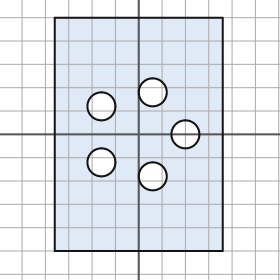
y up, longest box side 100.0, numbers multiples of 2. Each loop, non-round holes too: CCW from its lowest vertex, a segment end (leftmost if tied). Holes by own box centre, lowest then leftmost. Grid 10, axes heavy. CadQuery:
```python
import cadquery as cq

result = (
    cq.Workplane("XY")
    .moveTo(-36.0, -50.0)
    .lineTo(36.0, -50.0)
    .lineTo(36.0, 50.0)
    .lineTo(-36.0, 50.0)
    .close()
    .moveTo(6.0, -18.0)
    .circle(6.0)
    .moveTo(-16.0, -12.0)
    .circle(6.0)
    .moveTo(20.0, 0.0)
    .circle(6.0)
    .moveTo(-16.0, 12.0)
    .circle(6.0)
    .moveTo(6.0, 18.0)
    .circle(6.0)
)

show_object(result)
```